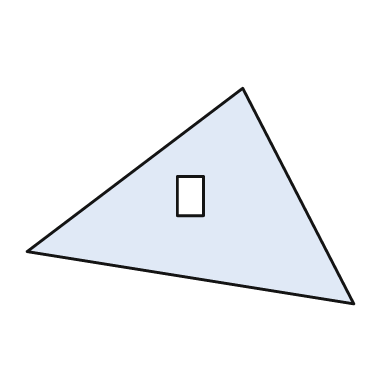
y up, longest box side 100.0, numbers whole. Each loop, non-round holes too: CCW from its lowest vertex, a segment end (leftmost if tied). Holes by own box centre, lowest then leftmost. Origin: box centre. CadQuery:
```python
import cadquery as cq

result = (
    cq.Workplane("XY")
    .moveTo(50.0, -33.0)
    .lineTo(16.0, 33.0)
    .lineTo(-50.0, -17.0)
    .close()
    .moveTo(-4.0, -6.0)
    .lineTo(4.0, -6.0)
    .lineTo(4.0, 6.0)
    .lineTo(-4.0, 6.0)
    .close()
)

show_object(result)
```